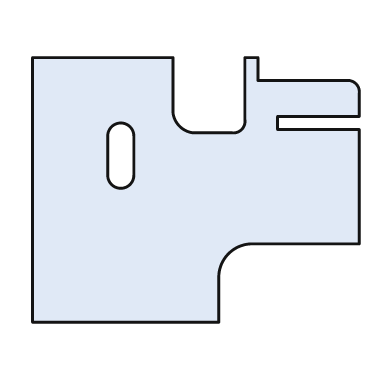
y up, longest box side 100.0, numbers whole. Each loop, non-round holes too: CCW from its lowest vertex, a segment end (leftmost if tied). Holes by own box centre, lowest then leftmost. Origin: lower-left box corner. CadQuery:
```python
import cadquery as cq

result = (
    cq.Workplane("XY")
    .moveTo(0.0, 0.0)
    .lineTo(57.0, 0.0)
    .lineTo(57.0, 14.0)
    .threePointArc((60.0, 21.0), (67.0, 24.0))
    .lineTo(100.0, 24.0)
    .lineTo(100.0, 59.0)
    .lineTo(75.0, 59.0)
    .lineTo(75.0, 63.0)
    .lineTo(100.0, 63.0)
    .lineTo(100.0, 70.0)
    .threePointArc((99.0, 73.0), (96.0, 74.0))
    .lineTo(69.0, 74.0)
    .lineTo(69.0, 81.0)
    .lineTo(65.0, 81.0)
    .lineTo(65.0, 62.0)
    .threePointArc((64.0, 59.0), (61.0, 58.0))
    .lineTo(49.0, 58.0)
    .threePointArc((45.0, 60.0), (43.0, 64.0))
    .lineTo(43.0, 81.0)
    .lineTo(0.0, 81.0)
    .close()
    .moveTo(23.0, 45.0)
    .threePointArc((27.0, 41.0), (31.0, 45.0))
    .lineTo(31.0, 57.0)
    .threePointArc((27.0, 61.0), (23.0, 57.0))
    .close()
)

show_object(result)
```